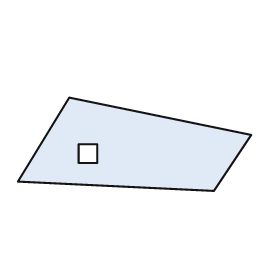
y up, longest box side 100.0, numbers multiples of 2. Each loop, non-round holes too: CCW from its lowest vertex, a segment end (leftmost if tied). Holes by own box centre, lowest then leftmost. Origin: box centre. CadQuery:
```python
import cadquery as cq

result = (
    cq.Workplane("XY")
    .moveTo(34.0, -20.0)
    .lineTo(50.0, 4.0)
    .lineTo(-28.0, 20.0)
    .lineTo(-50.0, -16.0)
    .close()
    .moveTo(-24.0, -8.0)
    .lineTo(-16.0, -8.0)
    .lineTo(-16.0, 0.0)
    .lineTo(-24.0, 0.0)
    .close()
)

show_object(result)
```